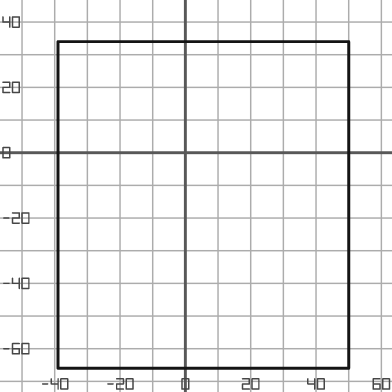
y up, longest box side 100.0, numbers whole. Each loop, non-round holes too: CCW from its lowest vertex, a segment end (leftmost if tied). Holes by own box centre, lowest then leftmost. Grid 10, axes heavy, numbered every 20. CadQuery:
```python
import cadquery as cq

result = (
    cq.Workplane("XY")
    .moveTo(-39.0, -66.0)
    .lineTo(50.0, -66.0)
    .lineTo(50.0, 34.0)
    .lineTo(-39.0, 34.0)
    .close()
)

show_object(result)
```